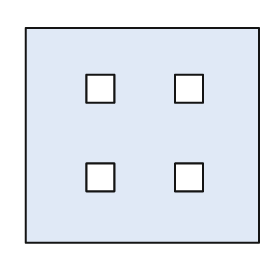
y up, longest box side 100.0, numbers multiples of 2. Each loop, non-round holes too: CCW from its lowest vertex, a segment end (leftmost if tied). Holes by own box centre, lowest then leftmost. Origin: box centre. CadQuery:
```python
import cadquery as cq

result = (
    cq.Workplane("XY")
    .moveTo(-50.0, -46.0)
    .lineTo(50.0, -46.0)
    .lineTo(50.0, 46.0)
    .lineTo(-50.0, 46.0)
    .close()
    .moveTo(-24.0, -24.0)
    .lineTo(-12.0, -24.0)
    .lineTo(-12.0, -12.0)
    .lineTo(-24.0, -12.0)
    .close()
    .moveTo(14.0, -24.0)
    .lineTo(26.0, -24.0)
    .lineTo(26.0, -12.0)
    .lineTo(14.0, -12.0)
    .close()
    .moveTo(-24.0, 14.0)
    .lineTo(-12.0, 14.0)
    .lineTo(-12.0, 26.0)
    .lineTo(-24.0, 26.0)
    .close()
    .moveTo(14.0, 14.0)
    .lineTo(26.0, 14.0)
    .lineTo(26.0, 26.0)
    .lineTo(14.0, 26.0)
    .close()
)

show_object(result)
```